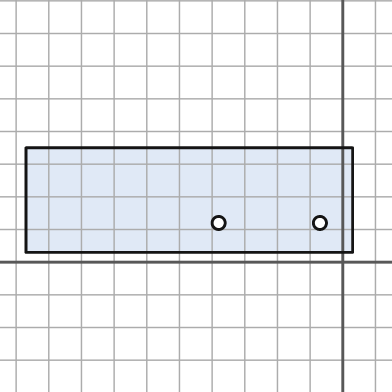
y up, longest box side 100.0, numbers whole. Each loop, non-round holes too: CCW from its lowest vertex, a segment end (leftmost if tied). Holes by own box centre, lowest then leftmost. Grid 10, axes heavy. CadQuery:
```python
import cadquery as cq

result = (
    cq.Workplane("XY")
    .moveTo(-97.0, 3.0)
    .lineTo(3.0, 3.0)
    .lineTo(3.0, 35.0)
    .lineTo(-97.0, 35.0)
    .close()
    .moveTo(-38.0, 12.0)
    .circle(2.0)
    .moveTo(-7.0, 12.0)
    .circle(2.0)
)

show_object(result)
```